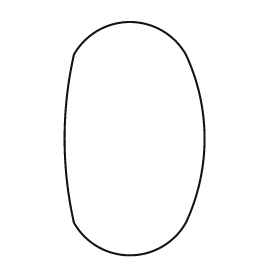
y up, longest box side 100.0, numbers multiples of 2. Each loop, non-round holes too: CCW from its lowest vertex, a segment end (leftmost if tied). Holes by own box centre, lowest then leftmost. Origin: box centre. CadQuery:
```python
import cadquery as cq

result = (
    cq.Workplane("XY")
    .moveTo(-26.0, -36.0)
    .threePointArc((-2.0, -50.0), (22.0, -36.0))
    .threePointArc((30.0, 0.0), (22.0, 36.0))
    .threePointArc((-2.0, 50.0), (-26.0, 36.0))
    .threePointArc((-30.0, 0.0), (-26.0, -36.0))
    .close()
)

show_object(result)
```